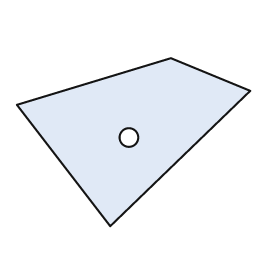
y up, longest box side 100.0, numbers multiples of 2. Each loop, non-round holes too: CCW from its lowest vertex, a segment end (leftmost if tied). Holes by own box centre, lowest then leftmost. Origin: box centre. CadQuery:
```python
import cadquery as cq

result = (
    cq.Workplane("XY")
    .moveTo(-10.0, -36.0)
    .lineTo(50.0, 22.0)
    .lineTo(16.0, 36.0)
    .lineTo(-50.0, 16.0)
    .close()
    .moveTo(-2.0, 2.0)
    .circle(4.0)
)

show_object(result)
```